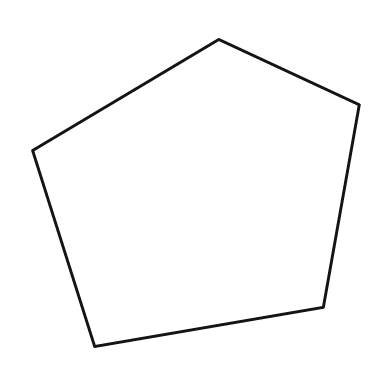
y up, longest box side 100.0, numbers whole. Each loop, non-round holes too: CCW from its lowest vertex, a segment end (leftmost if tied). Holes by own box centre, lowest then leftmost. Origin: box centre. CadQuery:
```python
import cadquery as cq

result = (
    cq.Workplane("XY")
    .moveTo(-31.0, -47.0)
    .lineTo(39.0, -35.0)
    .lineTo(50.0, 27.0)
    .lineTo(7.0, 47.0)
    .lineTo(-50.0, 13.0)
    .close()
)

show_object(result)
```